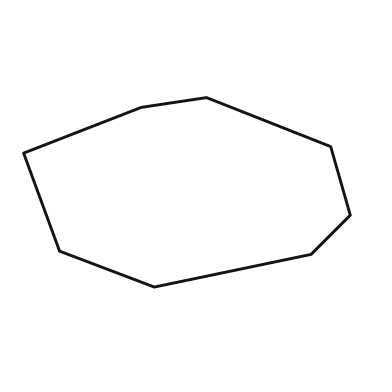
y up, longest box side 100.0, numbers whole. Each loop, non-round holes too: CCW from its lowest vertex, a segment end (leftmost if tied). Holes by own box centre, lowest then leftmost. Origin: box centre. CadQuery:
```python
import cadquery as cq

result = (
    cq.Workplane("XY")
    .moveTo(-10.0, -29.0)
    .lineTo(38.0, -19.0)
    .lineTo(50.0, -7.0)
    .lineTo(44.0, 14.0)
    .lineTo(6.0, 29.0)
    .lineTo(-14.0, 26.0)
    .lineTo(-50.0, 12.0)
    .lineTo(-39.0, -18.0)
    .close()
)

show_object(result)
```